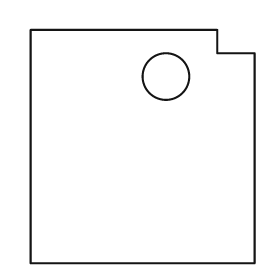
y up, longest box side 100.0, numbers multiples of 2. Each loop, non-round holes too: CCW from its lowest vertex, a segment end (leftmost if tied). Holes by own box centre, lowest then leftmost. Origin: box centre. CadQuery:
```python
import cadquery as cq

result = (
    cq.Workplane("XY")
    .moveTo(-48.0, -50.0)
    .lineTo(48.0, -50.0)
    .lineTo(48.0, 40.0)
    .lineTo(32.0, 40.0)
    .lineTo(32.0, 50.0)
    .lineTo(-48.0, 50.0)
    .close()
    .moveTo(10.0, 30.0)
    .circle(10.0)
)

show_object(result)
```